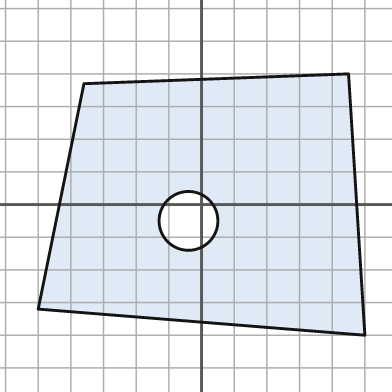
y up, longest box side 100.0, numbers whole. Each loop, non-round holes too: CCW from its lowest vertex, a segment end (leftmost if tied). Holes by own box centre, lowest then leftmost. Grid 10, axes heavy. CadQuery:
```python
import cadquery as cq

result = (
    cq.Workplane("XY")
    .moveTo(50.0, -40.0)
    .lineTo(45.0, 40.0)
    .lineTo(-36.0, 37.0)
    .lineTo(-50.0, -32.0)
    .close()
    .moveTo(-4.0, -5.0)
    .circle(9.0)
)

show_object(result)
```